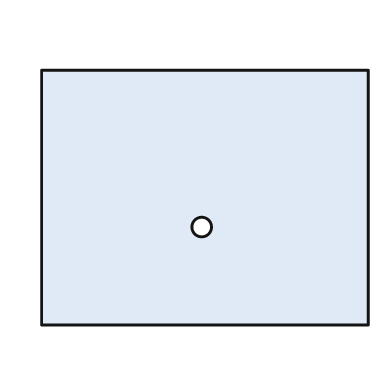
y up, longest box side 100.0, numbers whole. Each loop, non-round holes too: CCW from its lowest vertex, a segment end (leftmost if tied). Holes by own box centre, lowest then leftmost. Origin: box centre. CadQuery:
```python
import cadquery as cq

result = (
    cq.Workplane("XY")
    .moveTo(-50.0, -39.0)
    .lineTo(50.0, -39.0)
    .lineTo(50.0, 39.0)
    .lineTo(-50.0, 39.0)
    .close()
    .moveTo(-1.0, -9.0)
    .circle(3.0)
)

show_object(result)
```